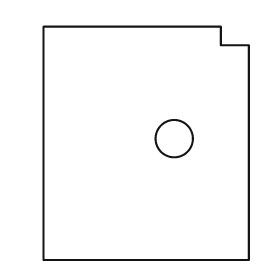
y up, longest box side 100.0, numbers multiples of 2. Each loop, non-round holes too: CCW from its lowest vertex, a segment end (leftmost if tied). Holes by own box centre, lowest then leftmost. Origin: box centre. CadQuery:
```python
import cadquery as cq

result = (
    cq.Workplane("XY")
    .moveTo(-44.0, -50.0)
    .lineTo(44.0, -50.0)
    .lineTo(44.0, 42.0)
    .lineTo(32.0, 42.0)
    .lineTo(32.0, 50.0)
    .lineTo(-44.0, 50.0)
    .close()
    .moveTo(12.0, 2.0)
    .circle(8.0)
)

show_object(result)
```